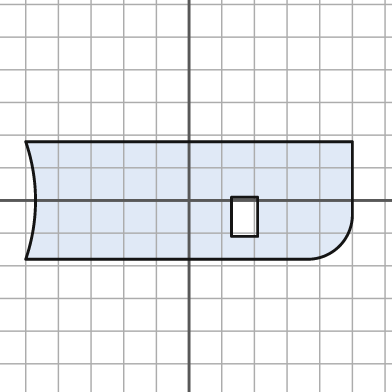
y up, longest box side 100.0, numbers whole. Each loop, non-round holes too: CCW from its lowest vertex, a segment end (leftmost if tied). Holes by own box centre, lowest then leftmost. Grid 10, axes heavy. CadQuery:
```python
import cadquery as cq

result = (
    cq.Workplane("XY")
    .moveTo(-50.0, -18.0)
    .lineTo(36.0, -18.0)
    .threePointArc((46.0, -14.0), (50.0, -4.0))
    .lineTo(50.0, 18.0)
    .lineTo(-50.0, 18.0)
    .threePointArc((-47.0, 0.0), (-50.0, -18.0))
    .close()
    .moveTo(13.0, -11.0)
    .lineTo(21.0, -11.0)
    .lineTo(21.0, 1.0)
    .lineTo(13.0, 1.0)
    .close()
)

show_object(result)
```